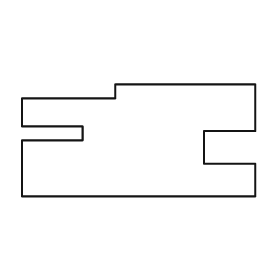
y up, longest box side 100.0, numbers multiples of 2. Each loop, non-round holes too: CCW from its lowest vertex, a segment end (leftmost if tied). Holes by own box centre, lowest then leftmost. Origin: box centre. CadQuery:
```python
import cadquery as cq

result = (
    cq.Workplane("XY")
    .moveTo(-50.0, -24.0)
    .lineTo(50.0, -24.0)
    .lineTo(50.0, -10.0)
    .lineTo(28.0, -10.0)
    .lineTo(28.0, 4.0)
    .lineTo(50.0, 4.0)
    .lineTo(50.0, 24.0)
    .lineTo(-10.0, 24.0)
    .lineTo(-10.0, 18.0)
    .lineTo(-50.0, 18.0)
    .lineTo(-50.0, 6.0)
    .lineTo(-24.0, 6.0)
    .lineTo(-24.0, 0.0)
    .lineTo(-50.0, 0.0)
    .close()
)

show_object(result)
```